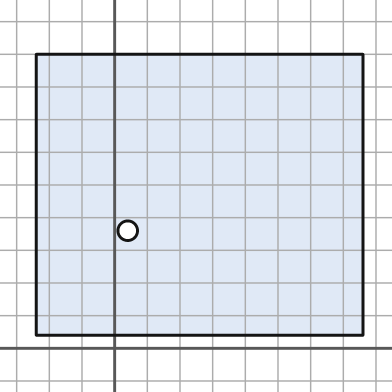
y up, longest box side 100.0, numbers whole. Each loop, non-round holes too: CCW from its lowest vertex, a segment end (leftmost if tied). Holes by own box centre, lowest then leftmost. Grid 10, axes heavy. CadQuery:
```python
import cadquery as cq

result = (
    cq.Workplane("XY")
    .moveTo(-24.0, 4.0)
    .lineTo(76.0, 4.0)
    .lineTo(76.0, 90.0)
    .lineTo(-24.0, 90.0)
    .close()
    .moveTo(4.0, 36.0)
    .circle(3.0)
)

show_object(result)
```